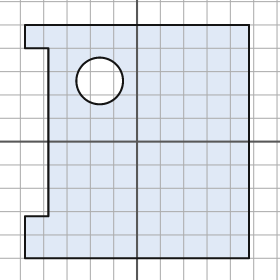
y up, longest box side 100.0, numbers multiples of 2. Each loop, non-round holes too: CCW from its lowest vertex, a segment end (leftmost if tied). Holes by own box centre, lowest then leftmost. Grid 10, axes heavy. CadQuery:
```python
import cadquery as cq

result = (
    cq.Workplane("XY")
    .moveTo(-48.0, -50.0)
    .lineTo(48.0, -50.0)
    .lineTo(48.0, 50.0)
    .lineTo(-48.0, 50.0)
    .lineTo(-48.0, 40.0)
    .lineTo(-38.0, 40.0)
    .lineTo(-38.0, -32.0)
    .lineTo(-48.0, -32.0)
    .close()
    .moveTo(-16.0, 26.0)
    .circle(10.0)
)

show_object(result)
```